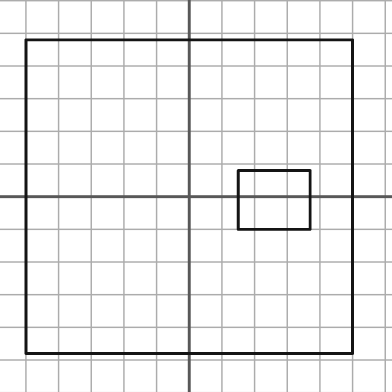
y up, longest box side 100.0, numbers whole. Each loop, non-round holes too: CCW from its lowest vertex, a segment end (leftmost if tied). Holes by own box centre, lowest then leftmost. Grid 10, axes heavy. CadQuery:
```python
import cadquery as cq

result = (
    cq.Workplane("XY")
    .moveTo(-50.0, -48.0)
    .lineTo(50.0, -48.0)
    .lineTo(50.0, 48.0)
    .lineTo(-50.0, 48.0)
    .close()
    .moveTo(15.0, -10.0)
    .lineTo(37.0, -10.0)
    .lineTo(37.0, 8.0)
    .lineTo(15.0, 8.0)
    .close()
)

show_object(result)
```